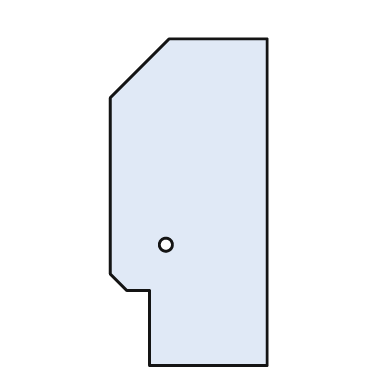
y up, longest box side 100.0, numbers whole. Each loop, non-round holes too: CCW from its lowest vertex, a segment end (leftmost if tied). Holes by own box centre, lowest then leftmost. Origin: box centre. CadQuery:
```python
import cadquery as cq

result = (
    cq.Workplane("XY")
    .moveTo(-12.0, -50.0)
    .lineTo(24.0, -50.0)
    .lineTo(24.0, 50.0)
    .lineTo(-6.0, 50.0)
    .lineTo(-24.0, 32.0)
    .lineTo(-24.0, -22.0)
    .lineTo(-19.0, -27.0)
    .lineTo(-12.0, -27.0)
    .close()
    .moveTo(-7.0, -13.0)
    .circle(2.0)
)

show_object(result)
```